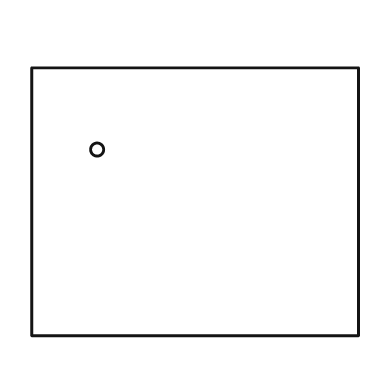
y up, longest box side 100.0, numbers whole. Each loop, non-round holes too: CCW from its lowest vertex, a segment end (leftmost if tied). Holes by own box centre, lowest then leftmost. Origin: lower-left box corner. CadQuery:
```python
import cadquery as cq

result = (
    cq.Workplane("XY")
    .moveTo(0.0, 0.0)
    .lineTo(100.0, 0.0)
    .lineTo(100.0, 82.0)
    .lineTo(0.0, 82.0)
    .close()
    .moveTo(20.0, 57.0)
    .circle(2.0)
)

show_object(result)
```